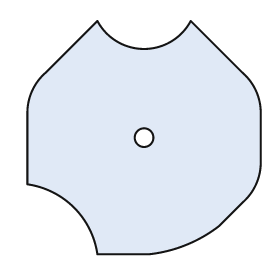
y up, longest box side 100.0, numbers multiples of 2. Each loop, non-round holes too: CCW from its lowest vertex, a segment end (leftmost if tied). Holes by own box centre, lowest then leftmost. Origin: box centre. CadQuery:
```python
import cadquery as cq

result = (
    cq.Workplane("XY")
    .moveTo(-20.0, -50.0)
    .lineTo(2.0, -50.0)
    .threePointArc((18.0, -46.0), (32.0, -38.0))
    .lineTo(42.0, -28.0)
    .threePointArc((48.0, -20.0), (50.0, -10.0))
    .lineTo(50.0, 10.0)
    .threePointArc((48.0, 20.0), (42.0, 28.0))
    .lineTo(20.0, 50.0)
    .threePointArc((0.0, 38.0), (-20.0, 50.0))
    .lineTo(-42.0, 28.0)
    .threePointArc((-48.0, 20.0), (-50.0, 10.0))
    .lineTo(-50.0, -20.0)
    .threePointArc((-30.0, -30.0), (-20.0, -50.0))
    .close()
    .moveTo(0.0, 0.0)
    .circle(4.0)
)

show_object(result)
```